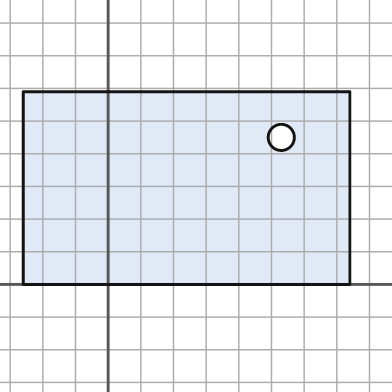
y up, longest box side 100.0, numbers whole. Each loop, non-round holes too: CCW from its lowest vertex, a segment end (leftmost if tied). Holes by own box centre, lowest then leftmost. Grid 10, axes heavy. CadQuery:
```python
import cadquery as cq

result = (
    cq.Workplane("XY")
    .moveTo(-26.0, 0.0)
    .lineTo(74.0, 0.0)
    .lineTo(74.0, 59.0)
    .lineTo(-26.0, 59.0)
    .close()
    .moveTo(53.0, 45.0)
    .circle(4.0)
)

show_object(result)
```